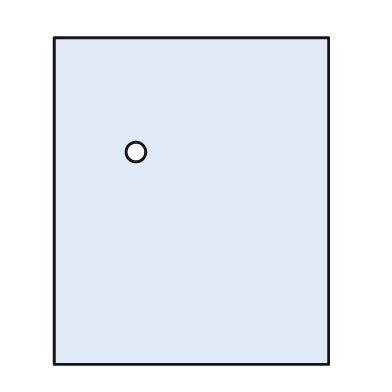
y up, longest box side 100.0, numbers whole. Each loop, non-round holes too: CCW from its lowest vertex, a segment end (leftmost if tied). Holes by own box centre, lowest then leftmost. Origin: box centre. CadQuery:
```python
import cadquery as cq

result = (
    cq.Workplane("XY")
    .moveTo(-42.0, -50.0)
    .lineTo(42.0, -50.0)
    .lineTo(42.0, 50.0)
    .lineTo(-42.0, 50.0)
    .close()
    .moveTo(-17.0, 15.0)
    .circle(3.0)
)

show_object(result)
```